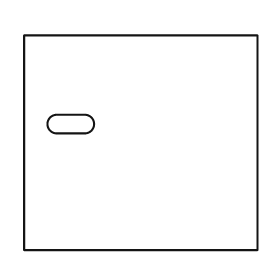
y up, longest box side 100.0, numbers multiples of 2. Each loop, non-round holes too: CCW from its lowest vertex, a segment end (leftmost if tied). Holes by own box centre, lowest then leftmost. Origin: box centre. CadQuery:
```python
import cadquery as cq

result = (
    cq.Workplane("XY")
    .moveTo(-50.0, -46.0)
    .lineTo(50.0, -46.0)
    .lineTo(50.0, 46.0)
    .lineTo(-50.0, 46.0)
    .close()
    .moveTo(-36.0, 4.0)
    .lineTo(-24.0, 4.0)
    .threePointArc((-20.0, 8.0), (-24.0, 12.0))
    .lineTo(-36.0, 12.0)
    .threePointArc((-40.0, 8.0), (-36.0, 4.0))
    .close()
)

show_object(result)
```